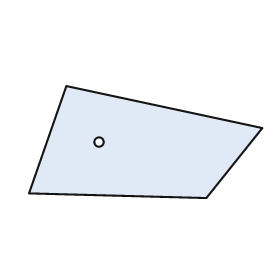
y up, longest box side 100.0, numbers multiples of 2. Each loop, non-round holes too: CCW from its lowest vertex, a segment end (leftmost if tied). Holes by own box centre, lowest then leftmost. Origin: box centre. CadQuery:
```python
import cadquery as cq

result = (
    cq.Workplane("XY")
    .moveTo(26.0, -24.0)
    .lineTo(50.0, 6.0)
    .lineTo(-34.0, 24.0)
    .lineTo(-50.0, -22.0)
    .close()
    .moveTo(-20.0, 0.0)
    .circle(2.0)
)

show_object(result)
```